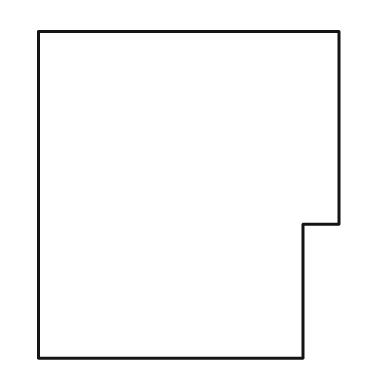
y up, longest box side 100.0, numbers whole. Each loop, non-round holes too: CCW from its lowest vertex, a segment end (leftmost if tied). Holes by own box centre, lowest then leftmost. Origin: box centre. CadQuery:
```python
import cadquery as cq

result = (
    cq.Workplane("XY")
    .moveTo(-46.0, -50.0)
    .lineTo(35.0, -50.0)
    .lineTo(35.0, -9.0)
    .lineTo(46.0, -9.0)
    .lineTo(46.0, 50.0)
    .lineTo(-46.0, 50.0)
    .close()
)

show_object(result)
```